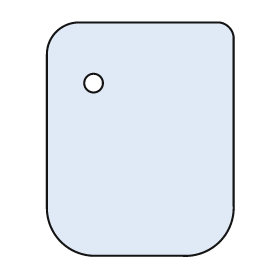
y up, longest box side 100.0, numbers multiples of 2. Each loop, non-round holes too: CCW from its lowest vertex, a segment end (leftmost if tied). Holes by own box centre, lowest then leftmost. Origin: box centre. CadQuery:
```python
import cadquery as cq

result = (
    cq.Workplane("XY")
    .moveTo(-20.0, -50.0)
    .lineTo(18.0, -50.0)
    .threePointArc((34.0, -44.0), (40.0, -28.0))
    .lineTo(40.0, 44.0)
    .threePointArc((38.0, 48.0), (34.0, 50.0))
    .lineTo(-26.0, 50.0)
    .threePointArc((-36.0, 46.0), (-40.0, 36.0))
    .lineTo(-40.0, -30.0)
    .threePointArc((-34.0, -44.0), (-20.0, -50.0))
    .close()
    .moveTo(-20.0, 24.0)
    .circle(4.0)
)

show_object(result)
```